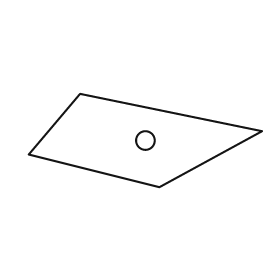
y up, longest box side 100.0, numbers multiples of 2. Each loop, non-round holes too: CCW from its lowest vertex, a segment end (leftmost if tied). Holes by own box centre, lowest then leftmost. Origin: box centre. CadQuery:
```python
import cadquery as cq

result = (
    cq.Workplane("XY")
    .moveTo(6.0, -20.0)
    .lineTo(50.0, 4.0)
    .lineTo(-28.0, 20.0)
    .lineTo(-50.0, -6.0)
    .close()
    .moveTo(0.0, 0.0)
    .circle(4.0)
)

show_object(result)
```